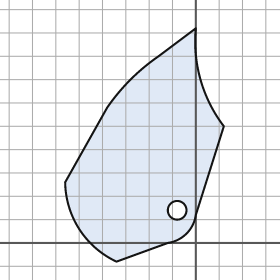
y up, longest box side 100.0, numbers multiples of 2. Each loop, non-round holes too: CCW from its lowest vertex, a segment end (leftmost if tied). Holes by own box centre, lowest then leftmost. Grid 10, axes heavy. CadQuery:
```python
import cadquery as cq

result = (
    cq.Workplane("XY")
    .moveTo(-34.0, -8.0)
    .lineTo(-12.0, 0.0)
    .threePointArc((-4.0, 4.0), (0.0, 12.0))
    .lineTo(12.0, 50.0)
    .threePointArc((2.0, 70.0), (0.0, 92.0))
    .lineTo(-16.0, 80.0)
    .threePointArc((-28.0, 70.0), (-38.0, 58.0))
    .lineTo(-56.0, 26.0)
    .threePointArc((-50.0, 6.0), (-34.0, -8.0))
    .close()
    .moveTo(-8.0, 14.0)
    .circle(4.0)
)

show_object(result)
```